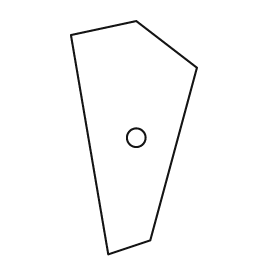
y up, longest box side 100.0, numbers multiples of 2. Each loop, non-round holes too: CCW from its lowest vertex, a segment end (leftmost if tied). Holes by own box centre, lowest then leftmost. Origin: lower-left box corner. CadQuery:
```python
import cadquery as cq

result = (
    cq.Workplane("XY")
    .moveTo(16.0, 0.0)
    .lineTo(34.0, 6.0)
    .lineTo(54.0, 80.0)
    .lineTo(28.0, 100.0)
    .lineTo(0.0, 94.0)
    .close()
    .moveTo(28.0, 50.0)
    .circle(4.0)
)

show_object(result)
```